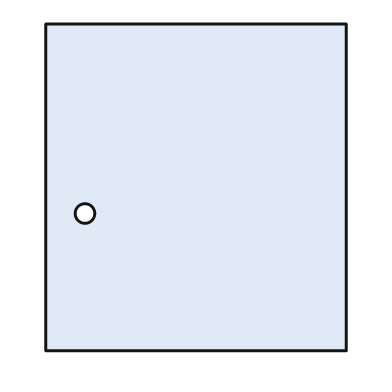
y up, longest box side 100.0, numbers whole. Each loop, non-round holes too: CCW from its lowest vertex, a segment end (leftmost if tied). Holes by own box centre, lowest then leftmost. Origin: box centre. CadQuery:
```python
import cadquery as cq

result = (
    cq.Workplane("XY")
    .moveTo(-46.0, -50.0)
    .lineTo(46.0, -50.0)
    .lineTo(46.0, 50.0)
    .lineTo(-46.0, 50.0)
    .close()
    .moveTo(-34.0, -8.0)
    .circle(3.0)
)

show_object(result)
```